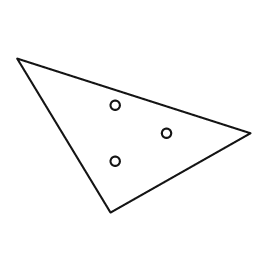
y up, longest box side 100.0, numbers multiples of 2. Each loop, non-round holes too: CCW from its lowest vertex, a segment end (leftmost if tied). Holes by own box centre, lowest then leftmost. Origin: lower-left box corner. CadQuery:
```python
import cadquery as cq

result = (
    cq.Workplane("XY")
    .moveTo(40.0, 0.0)
    .lineTo(100.0, 34.0)
    .lineTo(0.0, 66.0)
    .close()
    .moveTo(42.0, 22.0)
    .circle(2.0)
    .moveTo(64.0, 34.0)
    .circle(2.0)
    .moveTo(42.0, 46.0)
    .circle(2.0)
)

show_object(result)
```